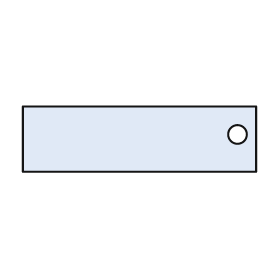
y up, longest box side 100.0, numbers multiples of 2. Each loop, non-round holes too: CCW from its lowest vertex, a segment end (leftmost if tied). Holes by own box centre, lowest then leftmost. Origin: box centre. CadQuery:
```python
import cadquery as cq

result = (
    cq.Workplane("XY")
    .moveTo(-50.0, -14.0)
    .lineTo(50.0, -14.0)
    .lineTo(50.0, 14.0)
    .lineTo(-50.0, 14.0)
    .close()
    .moveTo(42.0, 2.0)
    .circle(4.0)
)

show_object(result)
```